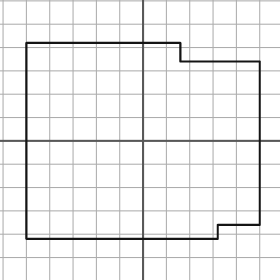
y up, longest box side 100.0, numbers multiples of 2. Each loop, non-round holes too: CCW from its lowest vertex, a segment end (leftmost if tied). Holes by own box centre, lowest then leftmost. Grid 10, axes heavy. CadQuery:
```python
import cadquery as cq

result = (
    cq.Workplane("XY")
    .moveTo(-50.0, -42.0)
    .lineTo(32.0, -42.0)
    .lineTo(32.0, -36.0)
    .lineTo(50.0, -36.0)
    .lineTo(50.0, 34.0)
    .lineTo(16.0, 34.0)
    .lineTo(16.0, 42.0)
    .lineTo(-50.0, 42.0)
    .close()
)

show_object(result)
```